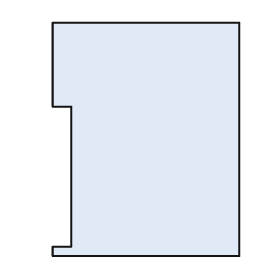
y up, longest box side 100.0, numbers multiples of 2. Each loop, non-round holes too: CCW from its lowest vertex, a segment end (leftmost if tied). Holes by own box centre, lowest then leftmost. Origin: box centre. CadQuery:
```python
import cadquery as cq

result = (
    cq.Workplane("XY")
    .moveTo(-40.0, -50.0)
    .lineTo(40.0, -50.0)
    .lineTo(40.0, 50.0)
    .lineTo(-40.0, 50.0)
    .lineTo(-40.0, 14.0)
    .lineTo(-32.0, 14.0)
    .lineTo(-32.0, -46.0)
    .lineTo(-40.0, -46.0)
    .close()
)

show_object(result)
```